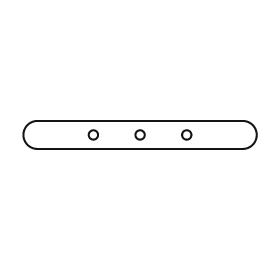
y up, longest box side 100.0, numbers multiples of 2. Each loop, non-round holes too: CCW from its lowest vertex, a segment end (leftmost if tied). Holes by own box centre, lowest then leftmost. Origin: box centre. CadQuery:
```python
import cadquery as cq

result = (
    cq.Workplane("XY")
    .moveTo(-44.0, -6.0)
    .lineTo(44.0, -6.0)
    .threePointArc((50.0, 0.0), (44.0, 6.0))
    .lineTo(-44.0, 6.0)
    .threePointArc((-50.0, 0.0), (-44.0, -6.0))
    .close()
    .moveTo(-20.0, 0.0)
    .circle(2.0)
    .moveTo(0.0, 0.0)
    .circle(2.0)
    .moveTo(20.0, 0.0)
    .circle(2.0)
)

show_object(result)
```